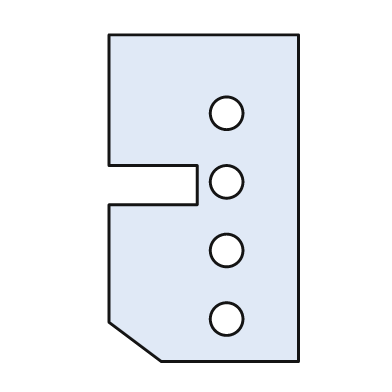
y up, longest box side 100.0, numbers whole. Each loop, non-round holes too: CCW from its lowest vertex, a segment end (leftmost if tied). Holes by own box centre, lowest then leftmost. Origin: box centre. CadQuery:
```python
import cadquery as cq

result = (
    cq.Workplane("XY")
    .moveTo(-13.0, -50.0)
    .lineTo(29.0, -50.0)
    .lineTo(29.0, 50.0)
    .lineTo(-29.0, 50.0)
    .lineTo(-29.0, 10.0)
    .lineTo(-2.0, 10.0)
    .lineTo(-2.0, -2.0)
    .lineTo(-29.0, -2.0)
    .lineTo(-29.0, -38.0)
    .close()
    .moveTo(7.0, -37.0)
    .circle(5.0)
    .moveTo(7.0, -16.0)
    .circle(5.0)
    .moveTo(7.0, 5.0)
    .circle(5.0)
    .moveTo(7.0, 26.0)
    .circle(5.0)
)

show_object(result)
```